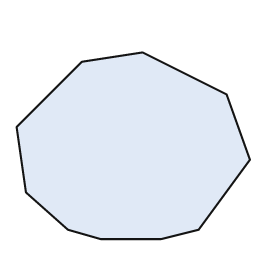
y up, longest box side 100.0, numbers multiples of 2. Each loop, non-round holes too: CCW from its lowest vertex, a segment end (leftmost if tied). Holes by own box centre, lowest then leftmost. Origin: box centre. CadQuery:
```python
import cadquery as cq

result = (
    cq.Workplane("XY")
    .moveTo(-14.0, -40.0)
    .lineTo(12.0, -40.0)
    .lineTo(28.0, -36.0)
    .lineTo(50.0, -6.0)
    .lineTo(40.0, 22.0)
    .lineTo(4.0, 40.0)
    .lineTo(-22.0, 36.0)
    .lineTo(-50.0, 8.0)
    .lineTo(-46.0, -20.0)
    .lineTo(-28.0, -36.0)
    .close()
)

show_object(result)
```